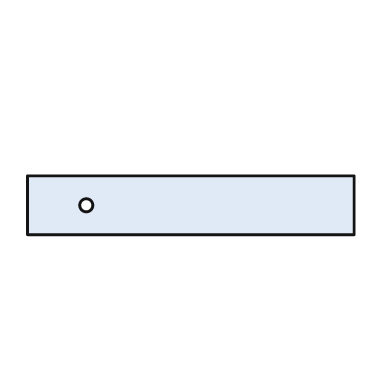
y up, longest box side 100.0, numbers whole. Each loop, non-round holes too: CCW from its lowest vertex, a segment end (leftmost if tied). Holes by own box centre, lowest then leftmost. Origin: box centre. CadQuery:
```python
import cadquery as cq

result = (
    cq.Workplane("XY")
    .moveTo(-50.0, -9.0)
    .lineTo(50.0, -9.0)
    .lineTo(50.0, 9.0)
    .lineTo(-50.0, 9.0)
    .close()
    .moveTo(-32.0, 0.0)
    .circle(2.0)
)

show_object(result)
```